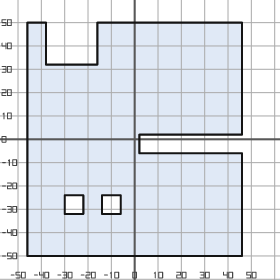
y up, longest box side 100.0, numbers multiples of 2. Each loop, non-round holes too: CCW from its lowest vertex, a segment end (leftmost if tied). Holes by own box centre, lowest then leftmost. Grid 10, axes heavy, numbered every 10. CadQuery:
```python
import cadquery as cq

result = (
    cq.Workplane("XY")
    .moveTo(-46.0, -50.0)
    .lineTo(46.0, -50.0)
    .lineTo(46.0, -6.0)
    .lineTo(2.0, -6.0)
    .lineTo(2.0, 2.0)
    .lineTo(46.0, 2.0)
    .lineTo(46.0, 50.0)
    .lineTo(-16.0, 50.0)
    .lineTo(-16.0, 32.0)
    .lineTo(-38.0, 32.0)
    .lineTo(-38.0, 50.0)
    .lineTo(-46.0, 50.0)
    .close()
    .moveTo(-30.0, -32.0)
    .lineTo(-22.0, -32.0)
    .lineTo(-22.0, -24.0)
    .lineTo(-30.0, -24.0)
    .close()
    .moveTo(-14.0, -32.0)
    .lineTo(-6.0, -32.0)
    .lineTo(-6.0, -24.0)
    .lineTo(-14.0, -24.0)
    .close()
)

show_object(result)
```